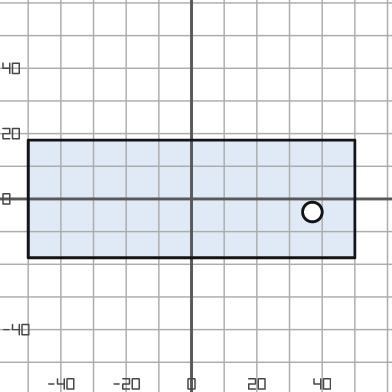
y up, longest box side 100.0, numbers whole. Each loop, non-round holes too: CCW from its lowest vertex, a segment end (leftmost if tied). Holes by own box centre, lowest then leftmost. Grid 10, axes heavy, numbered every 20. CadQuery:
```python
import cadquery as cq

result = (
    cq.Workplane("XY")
    .moveTo(-50.0, -18.0)
    .lineTo(50.0, -18.0)
    .lineTo(50.0, 18.0)
    .lineTo(-50.0, 18.0)
    .close()
    .moveTo(37.0, -4.0)
    .circle(3.0)
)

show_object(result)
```